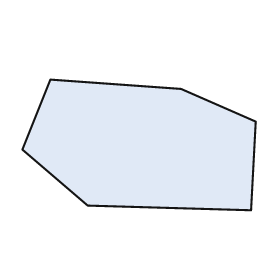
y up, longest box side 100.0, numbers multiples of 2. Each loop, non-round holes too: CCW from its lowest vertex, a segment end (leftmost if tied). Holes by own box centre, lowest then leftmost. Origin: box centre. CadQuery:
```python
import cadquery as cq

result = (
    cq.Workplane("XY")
    .moveTo(48.0, -28.0)
    .lineTo(50.0, 10.0)
    .lineTo(18.0, 24.0)
    .lineTo(-38.0, 28.0)
    .lineTo(-50.0, -2.0)
    .lineTo(-22.0, -26.0)
    .close()
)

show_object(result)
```